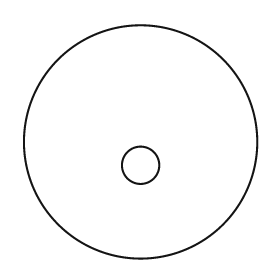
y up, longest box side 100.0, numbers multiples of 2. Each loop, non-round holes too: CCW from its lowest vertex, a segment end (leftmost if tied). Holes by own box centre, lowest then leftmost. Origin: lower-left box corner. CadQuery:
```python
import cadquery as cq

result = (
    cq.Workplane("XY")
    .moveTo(50.0, 50.0)
    .circle(50.0)
    .moveTo(50.0, 40.0)
    .circle(8.0)
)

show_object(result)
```